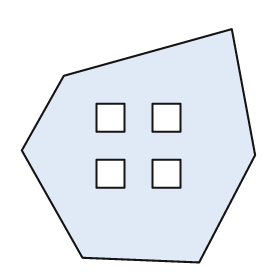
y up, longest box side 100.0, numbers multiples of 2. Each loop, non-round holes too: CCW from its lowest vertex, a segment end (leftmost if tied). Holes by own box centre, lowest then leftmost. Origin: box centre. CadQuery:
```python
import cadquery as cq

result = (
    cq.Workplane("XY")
    .moveTo(26.0, -50.0)
    .lineTo(50.0, -4.0)
    .lineTo(40.0, 50.0)
    .lineTo(-32.0, 30.0)
    .lineTo(-50.0, -2.0)
    .lineTo(-24.0, -48.0)
    .close()
    .moveTo(-18.0, -18.0)
    .lineTo(-6.0, -18.0)
    .lineTo(-6.0, -6.0)
    .lineTo(-18.0, -6.0)
    .close()
    .moveTo(6.0, -18.0)
    .lineTo(18.0, -18.0)
    .lineTo(18.0, -6.0)
    .lineTo(6.0, -6.0)
    .close()
    .moveTo(-18.0, 6.0)
    .lineTo(-6.0, 6.0)
    .lineTo(-6.0, 18.0)
    .lineTo(-18.0, 18.0)
    .close()
    .moveTo(6.0, 6.0)
    .lineTo(18.0, 6.0)
    .lineTo(18.0, 18.0)
    .lineTo(6.0, 18.0)
    .close()
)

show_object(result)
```